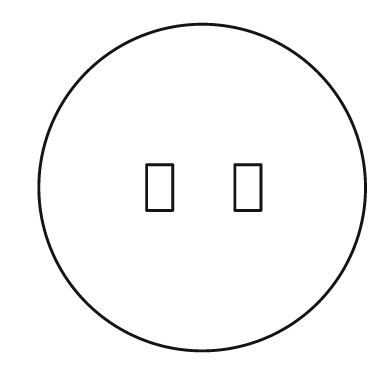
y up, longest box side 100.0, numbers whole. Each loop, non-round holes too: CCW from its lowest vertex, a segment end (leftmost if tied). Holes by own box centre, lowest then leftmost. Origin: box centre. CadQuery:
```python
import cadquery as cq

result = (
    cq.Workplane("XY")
    .moveTo(0.0, 0.0)
    .circle(50.0)
    .moveTo(-17.0, -7.0)
    .lineTo(-9.0, -7.0)
    .lineTo(-9.0, 7.0)
    .lineTo(-17.0, 7.0)
    .close()
    .moveTo(10.0, -7.0)
    .lineTo(18.0, -7.0)
    .lineTo(18.0, 7.0)
    .lineTo(10.0, 7.0)
    .close()
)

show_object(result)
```